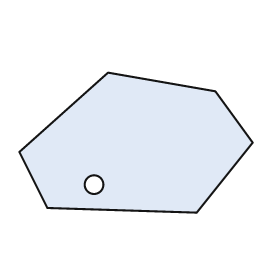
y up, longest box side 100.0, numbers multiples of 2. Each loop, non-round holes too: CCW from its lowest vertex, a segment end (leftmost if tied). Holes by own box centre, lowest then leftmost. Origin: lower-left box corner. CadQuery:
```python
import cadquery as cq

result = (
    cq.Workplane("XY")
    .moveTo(76.0, 0.0)
    .lineTo(100.0, 30.0)
    .lineTo(84.0, 52.0)
    .lineTo(38.0, 60.0)
    .lineTo(0.0, 26.0)
    .lineTo(12.0, 2.0)
    .close()
    .moveTo(32.0, 12.0)
    .circle(4.0)
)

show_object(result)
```